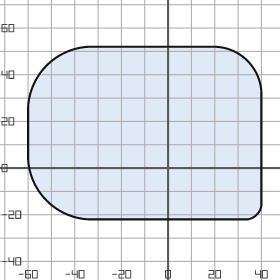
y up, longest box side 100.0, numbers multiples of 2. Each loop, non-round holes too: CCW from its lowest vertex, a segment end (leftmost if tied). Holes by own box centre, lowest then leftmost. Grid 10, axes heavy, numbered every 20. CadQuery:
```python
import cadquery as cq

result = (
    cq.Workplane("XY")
    .moveTo(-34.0, -22.0)
    .lineTo(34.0, -22.0)
    .threePointArc((38.0, -20.0), (40.0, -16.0))
    .lineTo(40.0, 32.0)
    .threePointArc((34.0, 46.0), (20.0, 52.0))
    .lineTo(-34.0, 52.0)
    .threePointArc((-52.0, 44.0), (-60.0, 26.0))
    .lineTo(-60.0, 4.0)
    .threePointArc((-52.0, -14.0), (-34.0, -22.0))
    .close()
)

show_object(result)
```